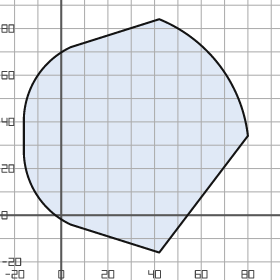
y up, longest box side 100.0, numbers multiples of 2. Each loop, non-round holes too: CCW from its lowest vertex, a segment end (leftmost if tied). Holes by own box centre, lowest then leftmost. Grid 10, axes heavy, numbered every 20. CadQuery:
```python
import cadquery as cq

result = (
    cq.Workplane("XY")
    .moveTo(42.0, -16.0)
    .lineTo(80.0, 34.0)
    .threePointArc((68.0, 64.0), (42.0, 84.0))
    .lineTo(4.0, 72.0)
    .threePointArc((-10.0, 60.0), (-16.0, 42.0))
    .lineTo(-16.0, 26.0)
    .threePointArc((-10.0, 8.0), (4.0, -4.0))
    .close()
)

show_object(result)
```